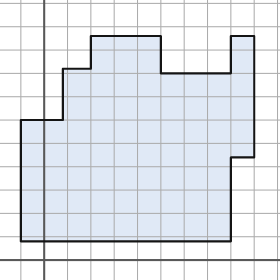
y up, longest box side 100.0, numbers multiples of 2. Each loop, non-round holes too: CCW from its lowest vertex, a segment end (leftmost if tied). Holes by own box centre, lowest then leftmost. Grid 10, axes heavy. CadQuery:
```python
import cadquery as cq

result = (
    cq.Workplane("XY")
    .moveTo(-10.0, 8.0)
    .lineTo(80.0, 8.0)
    .lineTo(80.0, 44.0)
    .lineTo(90.0, 44.0)
    .lineTo(90.0, 96.0)
    .lineTo(80.0, 96.0)
    .lineTo(80.0, 80.0)
    .lineTo(50.0, 80.0)
    .lineTo(50.0, 96.0)
    .lineTo(20.0, 96.0)
    .lineTo(20.0, 82.0)
    .lineTo(8.0, 82.0)
    .lineTo(8.0, 60.0)
    .lineTo(-10.0, 60.0)
    .close()
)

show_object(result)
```